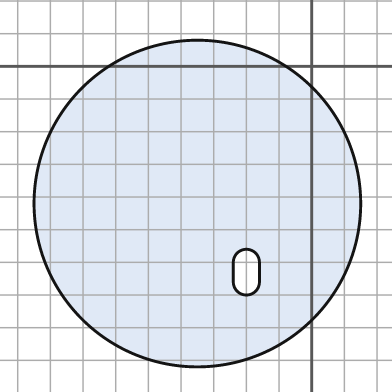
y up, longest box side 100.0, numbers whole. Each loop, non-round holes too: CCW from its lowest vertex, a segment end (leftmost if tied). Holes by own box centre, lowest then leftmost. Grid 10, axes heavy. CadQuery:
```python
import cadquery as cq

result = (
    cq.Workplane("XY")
    .moveTo(-35.0, -42.0)
    .circle(50.0)
    .moveTo(-24.0, -66.0)
    .threePointArc((-20.0, -70.0), (-16.0, -66.0))
    .lineTo(-16.0, -60.0)
    .threePointArc((-20.0, -56.0), (-24.0, -60.0))
    .close()
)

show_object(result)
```